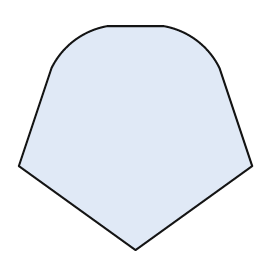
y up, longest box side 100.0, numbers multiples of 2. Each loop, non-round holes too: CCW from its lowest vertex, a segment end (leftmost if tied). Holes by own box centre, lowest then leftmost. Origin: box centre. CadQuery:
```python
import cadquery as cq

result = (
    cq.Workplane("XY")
    .moveTo(0.0, -48.0)
    .lineTo(50.0, -12.0)
    .lineTo(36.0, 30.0)
    .threePointArc((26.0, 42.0), (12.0, 48.0))
    .lineTo(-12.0, 48.0)
    .threePointArc((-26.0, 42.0), (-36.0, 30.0))
    .lineTo(-50.0, -12.0)
    .close()
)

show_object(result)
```